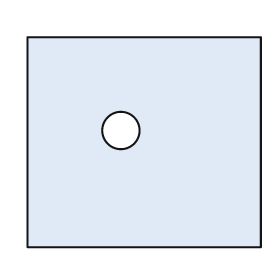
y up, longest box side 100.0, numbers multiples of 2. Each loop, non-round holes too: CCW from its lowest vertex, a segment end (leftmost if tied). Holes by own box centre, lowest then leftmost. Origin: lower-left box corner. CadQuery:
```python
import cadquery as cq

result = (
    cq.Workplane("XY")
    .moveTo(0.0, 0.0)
    .lineTo(100.0, 0.0)
    .lineTo(100.0, 90.0)
    .lineTo(0.0, 90.0)
    .close()
    .moveTo(40.0, 50.0)
    .circle(8.0)
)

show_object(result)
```